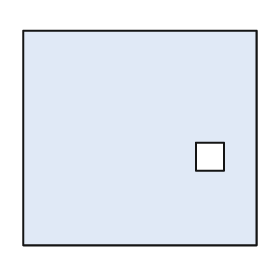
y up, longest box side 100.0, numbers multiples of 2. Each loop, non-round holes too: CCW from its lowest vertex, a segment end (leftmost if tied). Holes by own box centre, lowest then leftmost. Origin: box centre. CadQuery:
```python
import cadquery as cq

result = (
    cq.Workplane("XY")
    .moveTo(-50.0, -46.0)
    .lineTo(50.0, -46.0)
    .lineTo(50.0, 46.0)
    .lineTo(-50.0, 46.0)
    .close()
    .moveTo(24.0, -14.0)
    .lineTo(36.0, -14.0)
    .lineTo(36.0, -2.0)
    .lineTo(24.0, -2.0)
    .close()
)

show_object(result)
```